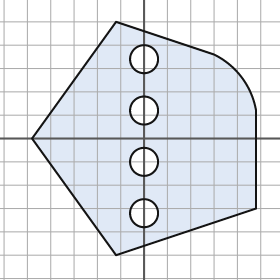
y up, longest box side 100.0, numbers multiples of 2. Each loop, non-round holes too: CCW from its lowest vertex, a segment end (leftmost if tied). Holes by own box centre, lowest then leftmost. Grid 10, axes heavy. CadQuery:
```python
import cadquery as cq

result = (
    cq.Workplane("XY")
    .moveTo(-12.0, -50.0)
    .lineTo(48.0, -30.0)
    .lineTo(48.0, 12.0)
    .threePointArc((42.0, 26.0), (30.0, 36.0))
    .lineTo(-12.0, 50.0)
    .lineTo(-48.0, 0.0)
    .close()
    .moveTo(0.0, -32.0)
    .circle(6.0)
    .moveTo(0.0, -10.0)
    .circle(6.0)
    .moveTo(0.0, 12.0)
    .circle(6.0)
    .moveTo(0.0, 34.0)
    .circle(6.0)
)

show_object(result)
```